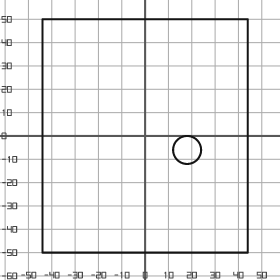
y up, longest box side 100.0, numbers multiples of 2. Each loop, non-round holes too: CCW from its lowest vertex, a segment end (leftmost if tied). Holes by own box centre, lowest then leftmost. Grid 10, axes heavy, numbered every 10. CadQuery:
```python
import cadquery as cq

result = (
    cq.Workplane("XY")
    .moveTo(-44.0, -50.0)
    .lineTo(44.0, -50.0)
    .lineTo(44.0, 50.0)
    .lineTo(-44.0, 50.0)
    .close()
    .moveTo(18.0, -6.0)
    .circle(6.0)
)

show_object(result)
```